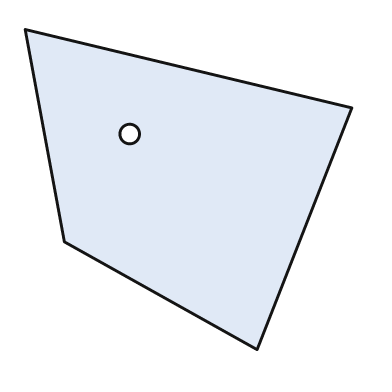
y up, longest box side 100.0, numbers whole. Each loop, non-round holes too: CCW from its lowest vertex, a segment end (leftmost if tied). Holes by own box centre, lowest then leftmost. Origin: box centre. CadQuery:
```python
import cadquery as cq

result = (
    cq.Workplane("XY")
    .moveTo(21.0, -49.0)
    .lineTo(50.0, 25.0)
    .lineTo(-50.0, 49.0)
    .lineTo(-38.0, -16.0)
    .close()
    .moveTo(-18.0, 17.0)
    .circle(3.0)
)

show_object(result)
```